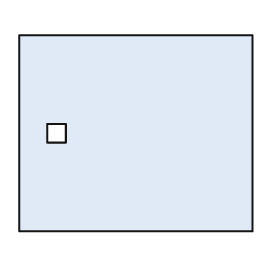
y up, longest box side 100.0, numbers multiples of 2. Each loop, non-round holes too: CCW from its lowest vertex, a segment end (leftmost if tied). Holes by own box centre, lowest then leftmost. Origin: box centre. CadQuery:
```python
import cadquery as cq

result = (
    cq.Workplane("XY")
    .moveTo(-50.0, -42.0)
    .lineTo(50.0, -42.0)
    .lineTo(50.0, 42.0)
    .lineTo(-50.0, 42.0)
    .close()
    .moveTo(-38.0, -4.0)
    .lineTo(-30.0, -4.0)
    .lineTo(-30.0, 4.0)
    .lineTo(-38.0, 4.0)
    .close()
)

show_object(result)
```